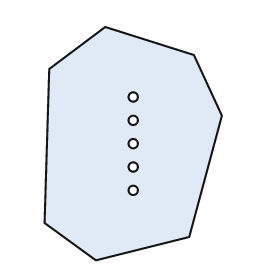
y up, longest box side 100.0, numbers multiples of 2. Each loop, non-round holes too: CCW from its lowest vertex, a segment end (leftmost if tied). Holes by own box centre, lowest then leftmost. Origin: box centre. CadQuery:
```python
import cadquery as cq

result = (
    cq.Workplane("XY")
    .moveTo(-16.0, -50.0)
    .lineTo(24.0, -40.0)
    .lineTo(38.0, 12.0)
    .lineTo(26.0, 38.0)
    .lineTo(-12.0, 50.0)
    .lineTo(-36.0, 32.0)
    .lineTo(-38.0, -34.0)
    .close()
    .moveTo(0.0, -20.0)
    .circle(2.0)
    .moveTo(0.0, -10.0)
    .circle(2.0)
    .moveTo(0.0, 0.0)
    .circle(2.0)
    .moveTo(0.0, 10.0)
    .circle(2.0)
    .moveTo(0.0, 20.0)
    .circle(2.0)
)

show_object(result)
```